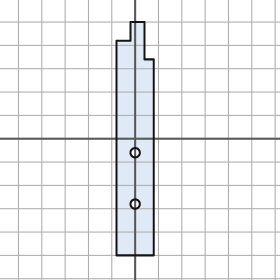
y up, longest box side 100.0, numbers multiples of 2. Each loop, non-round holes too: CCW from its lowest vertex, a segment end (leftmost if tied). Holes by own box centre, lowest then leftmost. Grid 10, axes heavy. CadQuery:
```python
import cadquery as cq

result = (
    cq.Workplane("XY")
    .moveTo(-8.0, -50.0)
    .lineTo(8.0, -50.0)
    .lineTo(8.0, 34.0)
    .lineTo(4.0, 34.0)
    .lineTo(4.0, 50.0)
    .lineTo(-2.0, 50.0)
    .lineTo(-2.0, 42.0)
    .lineTo(-8.0, 42.0)
    .close()
    .moveTo(0.0, -28.0)
    .circle(2.0)
    .moveTo(0.0, -6.0)
    .circle(2.0)
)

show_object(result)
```